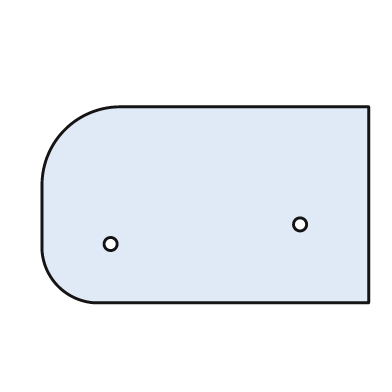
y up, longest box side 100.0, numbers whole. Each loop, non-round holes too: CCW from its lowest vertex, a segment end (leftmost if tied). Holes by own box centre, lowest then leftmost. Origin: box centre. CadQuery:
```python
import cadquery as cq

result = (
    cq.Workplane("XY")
    .moveTo(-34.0, -30.0)
    .lineTo(50.0, -30.0)
    .lineTo(50.0, 30.0)
    .lineTo(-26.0, 30.0)
    .threePointArc((-43.0, 23.0), (-50.0, 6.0))
    .lineTo(-50.0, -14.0)
    .threePointArc((-45.0, -25.0), (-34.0, -30.0))
    .close()
    .moveTo(-29.0, -12.0)
    .circle(2.0)
    .moveTo(29.0, -6.0)
    .circle(2.0)
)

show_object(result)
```